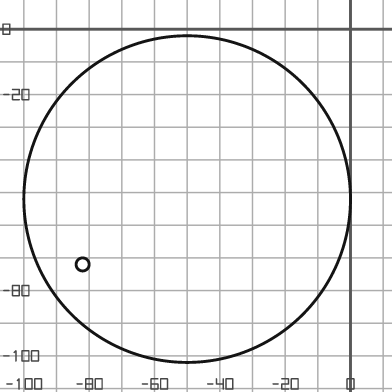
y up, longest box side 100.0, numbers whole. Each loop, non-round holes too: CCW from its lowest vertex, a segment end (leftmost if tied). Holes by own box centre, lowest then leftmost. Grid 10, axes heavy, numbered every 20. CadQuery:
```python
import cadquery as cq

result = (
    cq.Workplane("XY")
    .moveTo(-50.0, -52.0)
    .circle(50.0)
    .moveTo(-82.0, -72.0)
    .circle(2.0)
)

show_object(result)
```